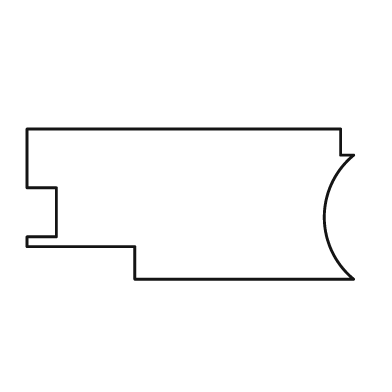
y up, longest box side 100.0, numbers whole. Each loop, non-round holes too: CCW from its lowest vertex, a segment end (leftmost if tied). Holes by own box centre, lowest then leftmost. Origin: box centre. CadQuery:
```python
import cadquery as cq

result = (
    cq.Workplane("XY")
    .moveTo(-17.0, -23.0)
    .lineTo(50.0, -23.0)
    .threePointArc((41.0, -4.0), (50.0, 15.0))
    .lineTo(46.0, 15.0)
    .lineTo(46.0, 23.0)
    .lineTo(-50.0, 23.0)
    .lineTo(-50.0, 5.0)
    .lineTo(-41.0, 5.0)
    .lineTo(-41.0, -10.0)
    .lineTo(-50.0, -10.0)
    .lineTo(-50.0, -13.0)
    .lineTo(-17.0, -13.0)
    .close()
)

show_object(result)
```